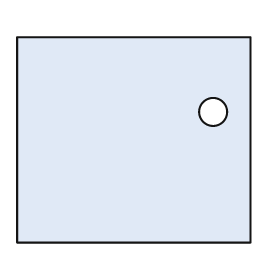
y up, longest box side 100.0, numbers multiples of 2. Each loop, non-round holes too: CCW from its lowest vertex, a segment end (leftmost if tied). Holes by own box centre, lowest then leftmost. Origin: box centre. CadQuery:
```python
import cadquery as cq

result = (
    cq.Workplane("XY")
    .moveTo(-50.0, -44.0)
    .lineTo(50.0, -44.0)
    .lineTo(50.0, 44.0)
    .lineTo(-50.0, 44.0)
    .close()
    .moveTo(34.0, 12.0)
    .circle(6.0)
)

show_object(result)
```